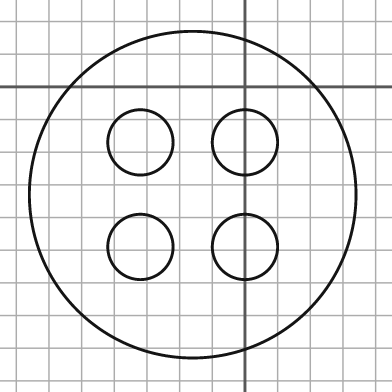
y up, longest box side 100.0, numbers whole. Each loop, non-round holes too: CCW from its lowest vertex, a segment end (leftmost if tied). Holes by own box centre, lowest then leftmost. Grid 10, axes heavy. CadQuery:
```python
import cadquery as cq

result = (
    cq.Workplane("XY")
    .moveTo(-16.0, -33.0)
    .circle(50.0)
    .moveTo(-32.0, -49.0)
    .circle(10.0)
    .moveTo(0.0, -49.0)
    .circle(10.0)
    .moveTo(-32.0, -17.0)
    .circle(10.0)
    .moveTo(0.0, -17.0)
    .circle(10.0)
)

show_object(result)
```